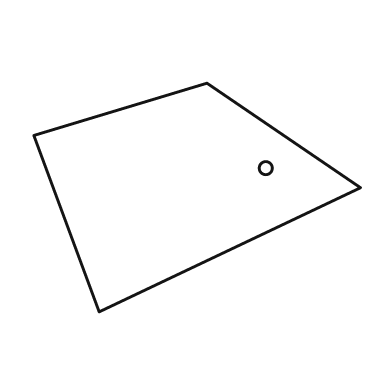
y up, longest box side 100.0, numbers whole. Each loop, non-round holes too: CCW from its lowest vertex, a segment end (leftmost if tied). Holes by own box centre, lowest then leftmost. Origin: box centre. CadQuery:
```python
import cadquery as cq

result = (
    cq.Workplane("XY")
    .moveTo(-30.0, -35.0)
    .lineTo(50.0, 3.0)
    .lineTo(3.0, 35.0)
    .lineTo(-50.0, 19.0)
    .close()
    .moveTo(21.0, 9.0)
    .circle(2.0)
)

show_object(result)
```